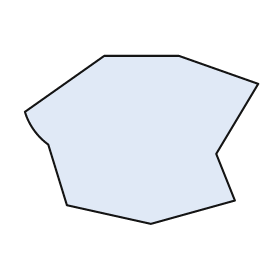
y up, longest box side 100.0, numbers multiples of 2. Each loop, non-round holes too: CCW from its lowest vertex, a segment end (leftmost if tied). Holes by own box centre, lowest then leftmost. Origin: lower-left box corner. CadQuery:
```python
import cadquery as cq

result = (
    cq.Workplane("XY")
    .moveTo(54.0, 0.0)
    .lineTo(90.0, 10.0)
    .lineTo(82.0, 30.0)
    .lineTo(100.0, 60.0)
    .lineTo(66.0, 72.0)
    .lineTo(34.0, 72.0)
    .lineTo(0.0, 48.0)
    .threePointArc((4.0, 40.0), (10.0, 34.0))
    .lineTo(18.0, 8.0)
    .close()
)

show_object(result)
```